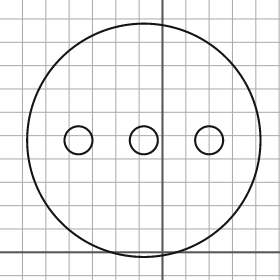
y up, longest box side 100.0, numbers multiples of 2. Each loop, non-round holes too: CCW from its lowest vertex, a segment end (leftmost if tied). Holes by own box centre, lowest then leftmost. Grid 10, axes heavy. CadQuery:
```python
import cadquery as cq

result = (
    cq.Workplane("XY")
    .moveTo(-8.0, 48.0)
    .circle(50.0)
    .moveTo(-36.0, 48.0)
    .circle(6.0)
    .moveTo(-8.0, 48.0)
    .circle(6.0)
    .moveTo(20.0, 48.0)
    .circle(6.0)
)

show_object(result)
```